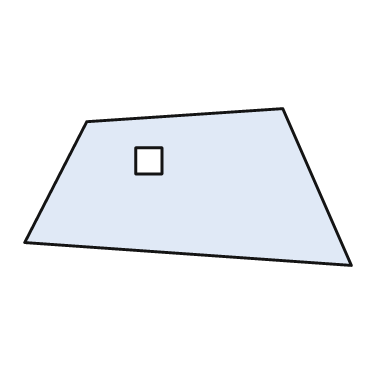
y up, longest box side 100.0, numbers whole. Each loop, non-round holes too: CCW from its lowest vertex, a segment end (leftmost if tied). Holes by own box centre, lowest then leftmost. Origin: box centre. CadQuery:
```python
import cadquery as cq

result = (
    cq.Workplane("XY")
    .moveTo(50.0, -24.0)
    .lineTo(29.0, 24.0)
    .lineTo(-31.0, 20.0)
    .lineTo(-50.0, -17.0)
    .close()
    .moveTo(-16.0, 4.0)
    .lineTo(-8.0, 4.0)
    .lineTo(-8.0, 12.0)
    .lineTo(-16.0, 12.0)
    .close()
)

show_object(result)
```